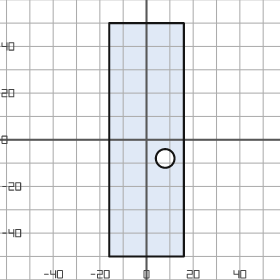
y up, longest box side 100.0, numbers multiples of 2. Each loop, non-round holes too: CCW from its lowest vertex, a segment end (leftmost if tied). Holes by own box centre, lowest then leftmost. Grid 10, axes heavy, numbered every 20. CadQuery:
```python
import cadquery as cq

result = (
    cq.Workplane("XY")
    .moveTo(-16.0, -50.0)
    .lineTo(16.0, -50.0)
    .lineTo(16.0, 50.0)
    .lineTo(-16.0, 50.0)
    .close()
    .moveTo(8.0, -8.0)
    .circle(4.0)
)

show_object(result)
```